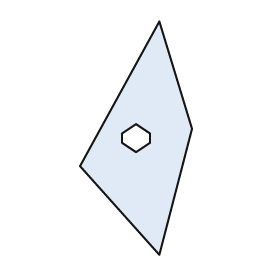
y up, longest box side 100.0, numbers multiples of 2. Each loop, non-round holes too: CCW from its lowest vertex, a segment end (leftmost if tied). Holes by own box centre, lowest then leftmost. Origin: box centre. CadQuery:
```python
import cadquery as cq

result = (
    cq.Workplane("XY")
    .moveTo(10.0, -50.0)
    .lineTo(24.0, 4.0)
    .lineTo(10.0, 50.0)
    .lineTo(-24.0, -12.0)
    .close()
    .moveTo(0.0, -6.0)
    .lineTo(6.0, -2.0)
    .lineTo(6.0, 2.0)
    .lineTo(0.0, 6.0)
    .lineTo(-6.0, 2.0)
    .lineTo(-6.0, -2.0)
    .close()
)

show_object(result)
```